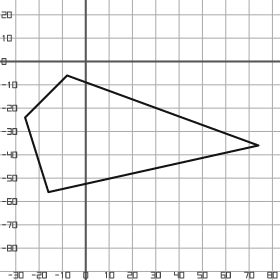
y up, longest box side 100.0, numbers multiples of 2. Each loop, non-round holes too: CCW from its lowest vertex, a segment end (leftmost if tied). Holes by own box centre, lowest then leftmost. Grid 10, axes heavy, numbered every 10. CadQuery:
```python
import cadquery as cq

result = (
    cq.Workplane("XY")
    .moveTo(-16.0, -56.0)
    .lineTo(74.0, -36.0)
    .lineTo(-8.0, -6.0)
    .lineTo(-26.0, -24.0)
    .close()
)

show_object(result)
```